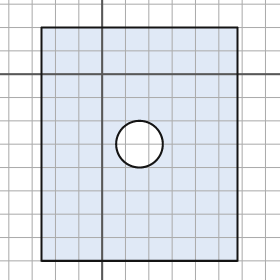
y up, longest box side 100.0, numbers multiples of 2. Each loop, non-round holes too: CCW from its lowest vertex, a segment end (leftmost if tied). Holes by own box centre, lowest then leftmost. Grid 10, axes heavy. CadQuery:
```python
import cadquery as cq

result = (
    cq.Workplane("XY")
    .moveTo(-26.0, -80.0)
    .lineTo(58.0, -80.0)
    .lineTo(58.0, 20.0)
    .lineTo(-26.0, 20.0)
    .close()
    .moveTo(16.0, -30.0)
    .circle(10.0)
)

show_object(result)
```